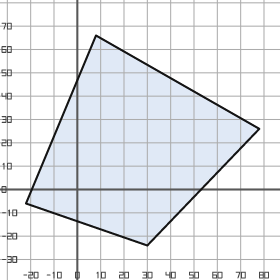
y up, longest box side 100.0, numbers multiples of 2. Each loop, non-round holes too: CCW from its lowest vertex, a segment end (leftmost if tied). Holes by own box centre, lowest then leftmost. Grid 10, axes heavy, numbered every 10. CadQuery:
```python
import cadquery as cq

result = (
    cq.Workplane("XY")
    .moveTo(30.0, -24.0)
    .lineTo(78.0, 26.0)
    .lineTo(8.0, 66.0)
    .lineTo(-22.0, -6.0)
    .close()
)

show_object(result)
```